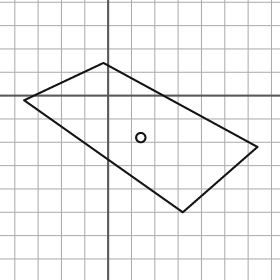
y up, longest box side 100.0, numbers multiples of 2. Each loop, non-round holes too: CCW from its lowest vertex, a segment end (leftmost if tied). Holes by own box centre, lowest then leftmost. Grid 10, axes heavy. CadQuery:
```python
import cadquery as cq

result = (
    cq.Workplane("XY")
    .moveTo(32.0, -50.0)
    .lineTo(64.0, -22.0)
    .lineTo(-2.0, 14.0)
    .lineTo(-36.0, -2.0)
    .close()
    .moveTo(14.0, -18.0)
    .circle(2.0)
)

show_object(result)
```